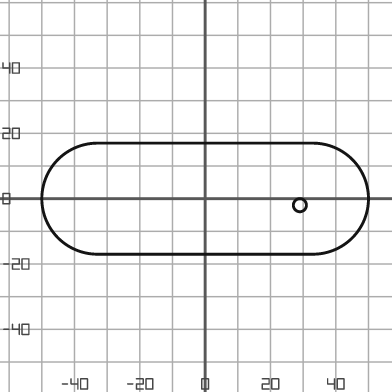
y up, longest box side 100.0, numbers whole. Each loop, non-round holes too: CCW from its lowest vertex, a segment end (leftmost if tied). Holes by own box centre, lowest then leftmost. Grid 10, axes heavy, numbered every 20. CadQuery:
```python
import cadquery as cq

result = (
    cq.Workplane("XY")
    .moveTo(-33.0, -17.0)
    .lineTo(33.0, -17.0)
    .threePointArc((50.0, 0.0), (33.0, 17.0))
    .lineTo(-33.0, 17.0)
    .threePointArc((-50.0, 0.0), (-33.0, -17.0))
    .close()
    .moveTo(29.0, -2.0)
    .circle(2.0)
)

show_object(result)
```